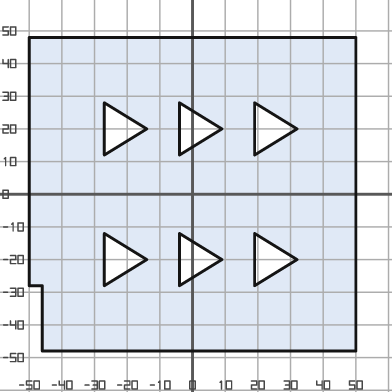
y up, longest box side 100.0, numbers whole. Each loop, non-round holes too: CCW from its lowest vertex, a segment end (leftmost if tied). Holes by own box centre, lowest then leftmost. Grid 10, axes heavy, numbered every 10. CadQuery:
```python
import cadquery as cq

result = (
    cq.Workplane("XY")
    .moveTo(-46.0, -48.0)
    .lineTo(50.0, -48.0)
    .lineTo(50.0, 48.0)
    .lineTo(-50.0, 48.0)
    .lineTo(-50.0, -28.0)
    .lineTo(-46.0, -28.0)
    .close()
    .moveTo(-27.0, -28.0)
    .lineTo(-14.0, -20.0)
    .lineTo(-27.0, -12.0)
    .close()
    .moveTo(-4.0, -28.0)
    .lineTo(9.0, -20.0)
    .lineTo(-4.0, -12.0)
    .close()
    .moveTo(19.0, -28.0)
    .lineTo(32.0, -20.0)
    .lineTo(19.0, -12.0)
    .close()
    .moveTo(-27.0, 12.0)
    .lineTo(-14.0, 20.0)
    .lineTo(-27.0, 28.0)
    .close()
    .moveTo(-4.0, 12.0)
    .lineTo(9.0, 20.0)
    .lineTo(-4.0, 28.0)
    .close()
    .moveTo(19.0, 12.0)
    .lineTo(32.0, 20.0)
    .lineTo(19.0, 28.0)
    .close()
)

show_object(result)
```